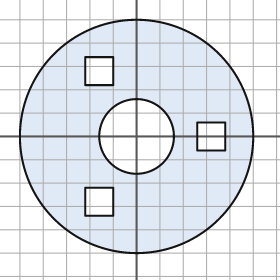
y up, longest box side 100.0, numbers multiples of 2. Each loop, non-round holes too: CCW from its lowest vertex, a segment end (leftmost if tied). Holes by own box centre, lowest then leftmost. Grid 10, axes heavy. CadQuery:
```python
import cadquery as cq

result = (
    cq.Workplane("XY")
    .moveTo(0.0, 0.0)
    .circle(50.0)
    .moveTo(-22.0, -34.0)
    .lineTo(-10.0, -34.0)
    .lineTo(-10.0, -22.0)
    .lineTo(-22.0, -22.0)
    .close()
    .moveTo(0.0, 0.0)
    .circle(16.0)
    .moveTo(26.0, -6.0)
    .lineTo(38.0, -6.0)
    .lineTo(38.0, 6.0)
    .lineTo(26.0, 6.0)
    .close()
    .moveTo(-22.0, 22.0)
    .lineTo(-10.0, 22.0)
    .lineTo(-10.0, 34.0)
    .lineTo(-22.0, 34.0)
    .close()
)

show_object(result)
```